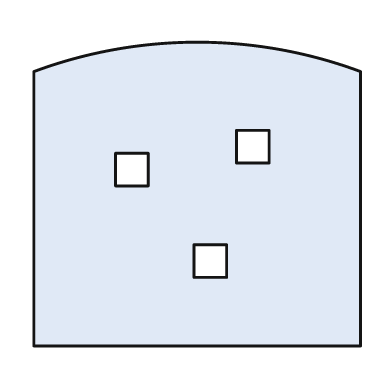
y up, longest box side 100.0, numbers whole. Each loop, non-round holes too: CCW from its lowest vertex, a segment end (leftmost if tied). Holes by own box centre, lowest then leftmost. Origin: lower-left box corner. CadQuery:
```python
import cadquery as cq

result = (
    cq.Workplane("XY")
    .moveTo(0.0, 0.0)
    .lineTo(100.0, 0.0)
    .lineTo(100.0, 84.0)
    .threePointArc((50.0, 93.0), (0.0, 84.0))
    .close()
    .moveTo(49.0, 21.0)
    .lineTo(59.0, 21.0)
    .lineTo(59.0, 31.0)
    .lineTo(49.0, 31.0)
    .close()
    .moveTo(25.0, 49.0)
    .lineTo(35.0, 49.0)
    .lineTo(35.0, 59.0)
    .lineTo(25.0, 59.0)
    .close()
    .moveTo(62.0, 56.0)
    .lineTo(72.0, 56.0)
    .lineTo(72.0, 66.0)
    .lineTo(62.0, 66.0)
    .close()
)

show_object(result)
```